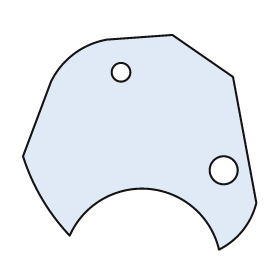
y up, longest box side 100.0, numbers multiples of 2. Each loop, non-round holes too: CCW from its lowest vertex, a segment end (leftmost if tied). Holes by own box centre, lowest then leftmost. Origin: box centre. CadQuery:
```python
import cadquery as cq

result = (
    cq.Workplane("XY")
    .moveTo(34.0, -46.0)
    .threePointArc((44.0, -38.0), (50.0, -26.0))
    .lineTo(40.0, 28.0)
    .lineTo(14.0, 46.0)
    .lineTo(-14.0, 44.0)
    .threePointArc((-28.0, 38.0), (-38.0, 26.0))
    .lineTo(-50.0, -6.0)
    .threePointArc((-42.0, -24.0), (-30.0, -40.0))
    .threePointArc((4.0, -20.0), (34.0, -46.0))
    .close()
    .moveTo(36.0, -12.0)
    .circle(6.0)
    .moveTo(-8.0, 30.0)
    .circle(4.0)
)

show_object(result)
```